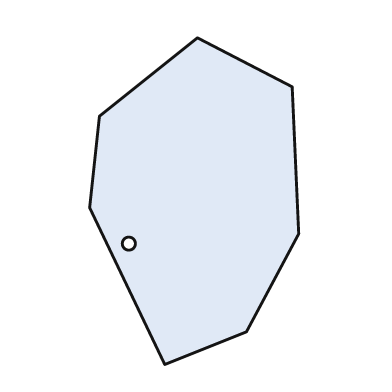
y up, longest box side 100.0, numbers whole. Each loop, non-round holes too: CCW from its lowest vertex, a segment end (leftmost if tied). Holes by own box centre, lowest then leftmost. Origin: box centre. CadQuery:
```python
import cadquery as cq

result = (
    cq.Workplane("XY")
    .moveTo(-9.0, -50.0)
    .lineTo(16.0, -40.0)
    .lineTo(32.0, -10.0)
    .lineTo(30.0, 35.0)
    .lineTo(1.0, 50.0)
    .lineTo(-29.0, 26.0)
    .lineTo(-32.0, -2.0)
    .close()
    .moveTo(-20.0, -13.0)
    .circle(2.0)
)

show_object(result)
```